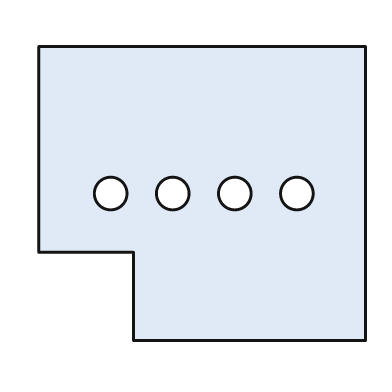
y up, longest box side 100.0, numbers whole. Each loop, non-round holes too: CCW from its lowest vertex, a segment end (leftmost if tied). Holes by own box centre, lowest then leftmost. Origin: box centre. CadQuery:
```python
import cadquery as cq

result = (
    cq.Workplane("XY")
    .moveTo(-21.0, -45.0)
    .lineTo(50.0, -45.0)
    .lineTo(50.0, 45.0)
    .lineTo(-50.0, 45.0)
    .lineTo(-50.0, -18.0)
    .lineTo(-21.0, -18.0)
    .close()
    .moveTo(-28.0, 0.0)
    .circle(5.0)
    .moveTo(-9.0, 0.0)
    .circle(5.0)
    .moveTo(10.0, 0.0)
    .circle(5.0)
    .moveTo(29.0, 0.0)
    .circle(5.0)
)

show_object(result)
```